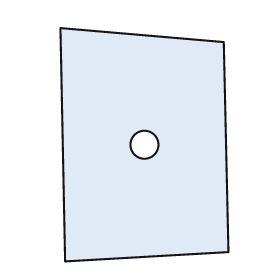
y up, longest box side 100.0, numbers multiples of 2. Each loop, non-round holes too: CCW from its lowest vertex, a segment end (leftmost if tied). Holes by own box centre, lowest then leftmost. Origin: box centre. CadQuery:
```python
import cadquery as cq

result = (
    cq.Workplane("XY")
    .moveTo(-34.0, -50.0)
    .lineTo(36.0, -46.0)
    .lineTo(34.0, 44.0)
    .lineTo(-36.0, 50.0)
    .close()
    .moveTo(0.0, 0.0)
    .circle(6.0)
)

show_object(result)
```